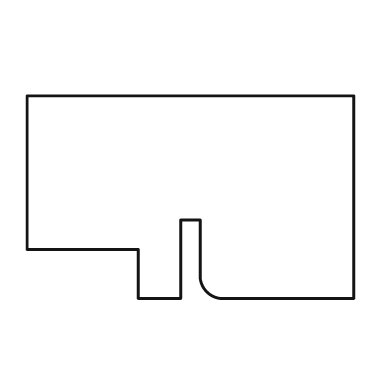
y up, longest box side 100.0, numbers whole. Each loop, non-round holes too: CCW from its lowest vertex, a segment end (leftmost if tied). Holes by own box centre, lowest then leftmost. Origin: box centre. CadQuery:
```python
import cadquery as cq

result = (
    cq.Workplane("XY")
    .moveTo(-16.0, -31.0)
    .lineTo(-3.0, -31.0)
    .lineTo(-3.0, -7.0)
    .lineTo(3.0, -7.0)
    .lineTo(3.0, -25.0)
    .threePointArc((5.0, -29.0), (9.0, -31.0))
    .lineTo(50.0, -31.0)
    .lineTo(50.0, 31.0)
    .lineTo(-50.0, 31.0)
    .lineTo(-50.0, -16.0)
    .lineTo(-16.0, -16.0)
    .close()
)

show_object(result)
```